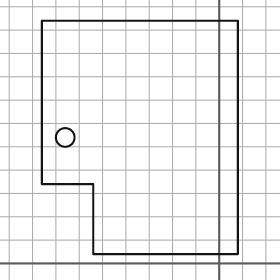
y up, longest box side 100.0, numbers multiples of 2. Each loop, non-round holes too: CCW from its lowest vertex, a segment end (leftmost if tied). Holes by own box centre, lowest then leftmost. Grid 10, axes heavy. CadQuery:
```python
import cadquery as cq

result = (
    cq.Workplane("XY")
    .moveTo(-54.0, 4.0)
    .lineTo(8.0, 4.0)
    .lineTo(8.0, 104.0)
    .lineTo(-76.0, 104.0)
    .lineTo(-76.0, 34.0)
    .lineTo(-54.0, 34.0)
    .close()
    .moveTo(-66.0, 54.0)
    .circle(4.0)
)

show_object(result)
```